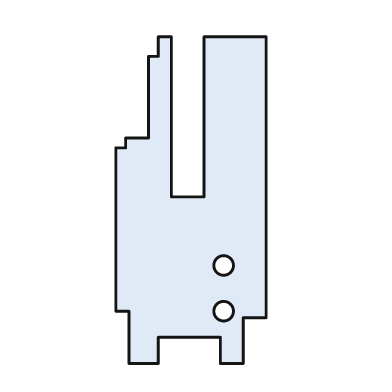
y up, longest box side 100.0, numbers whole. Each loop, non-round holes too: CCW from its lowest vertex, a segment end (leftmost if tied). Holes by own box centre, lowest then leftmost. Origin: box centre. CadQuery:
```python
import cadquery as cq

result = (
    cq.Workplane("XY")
    .moveTo(-19.0, -50.0)
    .lineTo(-10.0, -50.0)
    .lineTo(-10.0, -42.0)
    .lineTo(9.0, -42.0)
    .lineTo(9.0, -50.0)
    .lineTo(16.0, -50.0)
    .lineTo(16.0, -36.0)
    .lineTo(23.0, -36.0)
    .lineTo(23.0, 50.0)
    .lineTo(4.0, 50.0)
    .lineTo(4.0, 1.0)
    .lineTo(-6.0, 1.0)
    .lineTo(-6.0, 50.0)
    .lineTo(-10.0, 50.0)
    .lineTo(-10.0, 44.0)
    .lineTo(-13.0, 44.0)
    .lineTo(-13.0, 19.0)
    .lineTo(-20.0, 19.0)
    .lineTo(-20.0, 16.0)
    .lineTo(-23.0, 16.0)
    .lineTo(-23.0, -34.0)
    .lineTo(-19.0, -34.0)
    .close()
    .moveTo(10.0, -34.0)
    .circle(3.0)
    .moveTo(10.0, -20.0)
    .circle(3.0)
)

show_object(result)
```